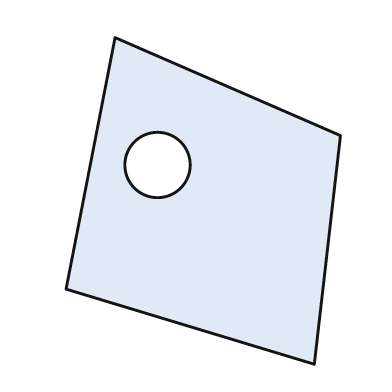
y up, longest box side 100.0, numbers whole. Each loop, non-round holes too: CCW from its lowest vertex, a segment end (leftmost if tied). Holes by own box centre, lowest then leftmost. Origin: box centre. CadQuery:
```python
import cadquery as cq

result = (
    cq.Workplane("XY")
    .moveTo(34.0, -50.0)
    .lineTo(42.0, 20.0)
    .lineTo(-27.0, 50.0)
    .lineTo(-42.0, -27.0)
    .close()
    .moveTo(-14.0, 11.0)
    .circle(10.0)
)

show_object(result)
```